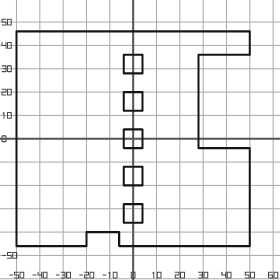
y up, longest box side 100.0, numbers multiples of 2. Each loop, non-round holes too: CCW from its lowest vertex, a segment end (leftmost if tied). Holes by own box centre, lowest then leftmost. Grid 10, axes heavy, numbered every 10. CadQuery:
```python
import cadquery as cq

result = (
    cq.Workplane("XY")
    .moveTo(-50.0, -46.0)
    .lineTo(-20.0, -46.0)
    .lineTo(-20.0, -40.0)
    .lineTo(-6.0, -40.0)
    .lineTo(-6.0, -46.0)
    .lineTo(50.0, -46.0)
    .lineTo(50.0, -4.0)
    .lineTo(28.0, -4.0)
    .lineTo(28.0, 36.0)
    .lineTo(50.0, 36.0)
    .lineTo(50.0, 46.0)
    .lineTo(-50.0, 46.0)
    .close()
    .moveTo(-4.0, -36.0)
    .lineTo(4.0, -36.0)
    .lineTo(4.0, -28.0)
    .lineTo(-4.0, -28.0)
    .close()
    .moveTo(-4.0, -20.0)
    .lineTo(4.0, -20.0)
    .lineTo(4.0, -12.0)
    .lineTo(-4.0, -12.0)
    .close()
    .moveTo(-4.0, -4.0)
    .lineTo(4.0, -4.0)
    .lineTo(4.0, 4.0)
    .lineTo(-4.0, 4.0)
    .close()
    .moveTo(-4.0, 12.0)
    .lineTo(4.0, 12.0)
    .lineTo(4.0, 20.0)
    .lineTo(-4.0, 20.0)
    .close()
    .moveTo(-4.0, 28.0)
    .lineTo(4.0, 28.0)
    .lineTo(4.0, 36.0)
    .lineTo(-4.0, 36.0)
    .close()
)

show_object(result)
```